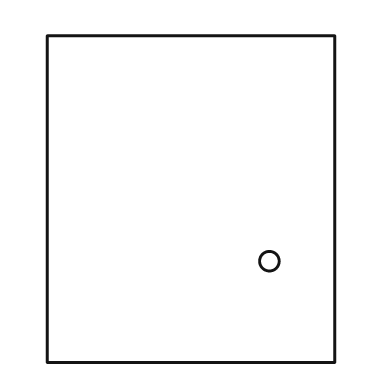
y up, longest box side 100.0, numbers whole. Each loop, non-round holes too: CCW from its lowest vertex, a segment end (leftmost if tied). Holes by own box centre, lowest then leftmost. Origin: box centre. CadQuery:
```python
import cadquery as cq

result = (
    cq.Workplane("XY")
    .moveTo(-44.0, -50.0)
    .lineTo(44.0, -50.0)
    .lineTo(44.0, 50.0)
    .lineTo(-44.0, 50.0)
    .close()
    .moveTo(24.0, -19.0)
    .circle(3.0)
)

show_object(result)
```